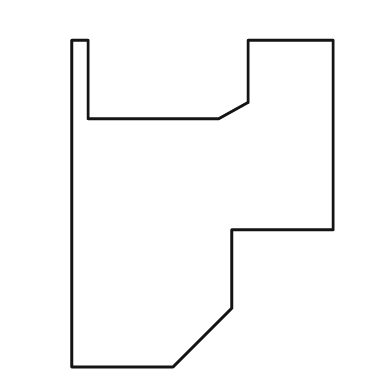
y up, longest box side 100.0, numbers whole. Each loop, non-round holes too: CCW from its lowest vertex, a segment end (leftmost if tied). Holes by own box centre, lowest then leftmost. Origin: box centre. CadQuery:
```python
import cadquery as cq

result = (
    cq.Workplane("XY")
    .moveTo(-40.0, -50.0)
    .lineTo(-9.0, -50.0)
    .lineTo(9.0, -32.0)
    .lineTo(9.0, -8.0)
    .lineTo(40.0, -8.0)
    .lineTo(40.0, 50.0)
    .lineTo(14.0, 50.0)
    .lineTo(14.0, 31.0)
    .lineTo(5.0, 26.0)
    .lineTo(-35.0, 26.0)
    .lineTo(-35.0, 50.0)
    .lineTo(-40.0, 50.0)
    .close()
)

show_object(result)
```